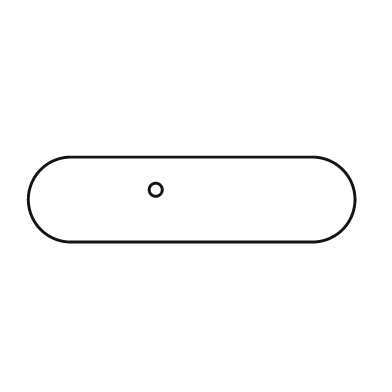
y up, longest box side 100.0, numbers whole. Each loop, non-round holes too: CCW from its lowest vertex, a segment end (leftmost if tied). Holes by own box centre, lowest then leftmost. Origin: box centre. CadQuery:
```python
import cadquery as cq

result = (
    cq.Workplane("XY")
    .moveTo(-37.0, -13.0)
    .lineTo(37.0, -13.0)
    .threePointArc((50.0, 0.0), (37.0, 13.0))
    .lineTo(-37.0, 13.0)
    .threePointArc((-50.0, 0.0), (-37.0, -13.0))
    .close()
    .moveTo(-11.0, 3.0)
    .circle(2.0)
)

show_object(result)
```